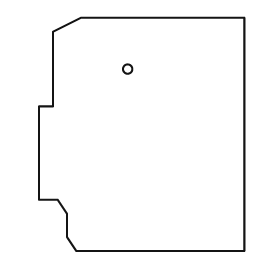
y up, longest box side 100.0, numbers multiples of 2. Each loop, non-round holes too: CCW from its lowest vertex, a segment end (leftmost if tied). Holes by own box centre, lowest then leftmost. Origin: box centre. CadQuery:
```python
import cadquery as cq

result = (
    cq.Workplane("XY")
    .moveTo(-28.0, -50.0)
    .lineTo(44.0, -50.0)
    .lineTo(44.0, 50.0)
    .lineTo(-26.0, 50.0)
    .lineTo(-38.0, 44.0)
    .lineTo(-38.0, 12.0)
    .lineTo(-44.0, 12.0)
    .lineTo(-44.0, -28.0)
    .lineTo(-36.0, -28.0)
    .lineTo(-32.0, -34.0)
    .lineTo(-32.0, -44.0)
    .close()
    .moveTo(-6.0, 28.0)
    .circle(2.0)
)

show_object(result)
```